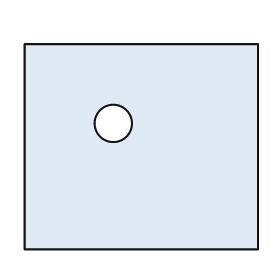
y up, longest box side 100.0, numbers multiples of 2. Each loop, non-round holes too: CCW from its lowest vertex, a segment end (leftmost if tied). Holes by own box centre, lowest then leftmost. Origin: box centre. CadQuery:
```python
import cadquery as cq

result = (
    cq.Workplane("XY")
    .moveTo(-50.0, -44.0)
    .lineTo(50.0, -44.0)
    .lineTo(50.0, 44.0)
    .lineTo(-50.0, 44.0)
    .close()
    .moveTo(-12.0, 10.0)
    .circle(8.0)
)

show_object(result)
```